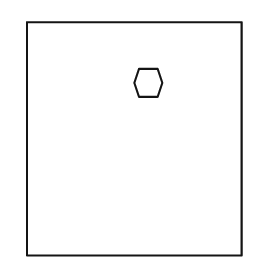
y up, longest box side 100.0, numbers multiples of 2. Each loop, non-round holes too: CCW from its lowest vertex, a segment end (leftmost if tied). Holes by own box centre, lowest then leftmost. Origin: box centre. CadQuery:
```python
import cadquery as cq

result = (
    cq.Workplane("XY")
    .moveTo(-46.0, -50.0)
    .lineTo(46.0, -50.0)
    .lineTo(46.0, 50.0)
    .lineTo(-46.0, 50.0)
    .close()
    .moveTo(2.0, 18.0)
    .lineTo(10.0, 18.0)
    .lineTo(12.0, 24.0)
    .lineTo(10.0, 30.0)
    .lineTo(2.0, 30.0)
    .lineTo(0.0, 24.0)
    .close()
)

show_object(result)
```